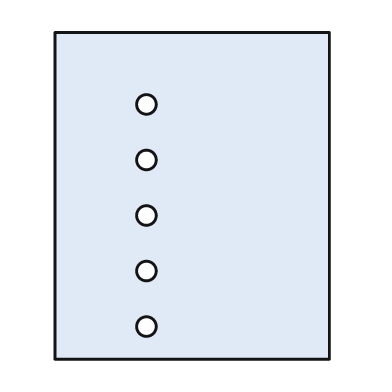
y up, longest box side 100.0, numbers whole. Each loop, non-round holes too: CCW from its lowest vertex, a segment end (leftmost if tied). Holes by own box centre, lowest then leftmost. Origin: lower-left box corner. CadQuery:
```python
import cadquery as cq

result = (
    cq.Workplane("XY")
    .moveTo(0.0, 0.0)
    .lineTo(84.0, 0.0)
    .lineTo(84.0, 100.0)
    .lineTo(0.0, 100.0)
    .close()
    .moveTo(28.0, 10.0)
    .circle(3.0)
    .moveTo(28.0, 27.0)
    .circle(3.0)
    .moveTo(28.0, 44.0)
    .circle(3.0)
    .moveTo(28.0, 61.0)
    .circle(3.0)
    .moveTo(28.0, 78.0)
    .circle(3.0)
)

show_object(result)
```